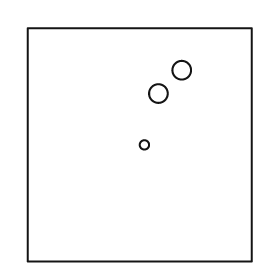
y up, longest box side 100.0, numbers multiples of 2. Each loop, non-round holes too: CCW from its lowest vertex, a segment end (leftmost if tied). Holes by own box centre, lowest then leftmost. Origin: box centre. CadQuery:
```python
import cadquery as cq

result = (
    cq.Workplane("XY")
    .moveTo(-48.0, -50.0)
    .lineTo(48.0, -50.0)
    .lineTo(48.0, 50.0)
    .lineTo(-48.0, 50.0)
    .close()
    .moveTo(2.0, 0.0)
    .circle(2.0)
    .moveTo(8.0, 22.0)
    .circle(4.0)
    .moveTo(18.0, 32.0)
    .circle(4.0)
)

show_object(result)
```